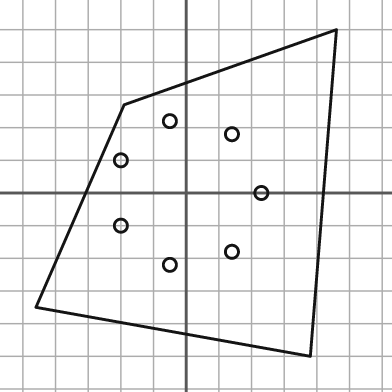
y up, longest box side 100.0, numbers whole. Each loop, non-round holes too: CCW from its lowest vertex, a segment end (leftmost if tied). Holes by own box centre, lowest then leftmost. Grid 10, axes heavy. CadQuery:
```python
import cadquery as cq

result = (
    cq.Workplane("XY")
    .moveTo(38.0, -50.0)
    .lineTo(46.0, 50.0)
    .lineTo(-19.0, 27.0)
    .lineTo(-46.0, -35.0)
    .close()
    .moveTo(-5.0, -22.0)
    .circle(2.0)
    .moveTo(14.0, -18.0)
    .circle(2.0)
    .moveTo(-20.0, -10.0)
    .circle(2.0)
    .moveTo(23.0, 0.0)
    .circle(2.0)
    .moveTo(-20.0, 10.0)
    .circle(2.0)
    .moveTo(14.0, 18.0)
    .circle(2.0)
    .moveTo(-5.0, 22.0)
    .circle(2.0)
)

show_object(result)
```